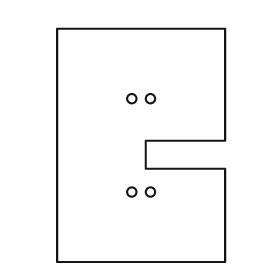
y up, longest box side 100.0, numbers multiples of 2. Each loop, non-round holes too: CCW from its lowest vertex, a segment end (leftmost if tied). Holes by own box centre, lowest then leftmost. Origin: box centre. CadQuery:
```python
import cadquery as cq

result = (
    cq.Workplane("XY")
    .moveTo(-36.0, -50.0)
    .lineTo(36.0, -50.0)
    .lineTo(36.0, -10.0)
    .lineTo(2.0, -10.0)
    .lineTo(2.0, 2.0)
    .lineTo(36.0, 2.0)
    .lineTo(36.0, 50.0)
    .lineTo(-36.0, 50.0)
    .close()
    .moveTo(-4.0, -20.0)
    .circle(2.0)
    .moveTo(4.0, -20.0)
    .circle(2.0)
    .moveTo(-4.0, 20.0)
    .circle(2.0)
    .moveTo(4.0, 20.0)
    .circle(2.0)
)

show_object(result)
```